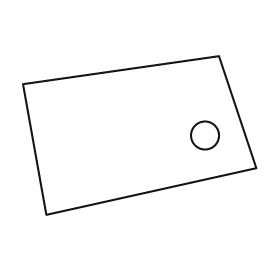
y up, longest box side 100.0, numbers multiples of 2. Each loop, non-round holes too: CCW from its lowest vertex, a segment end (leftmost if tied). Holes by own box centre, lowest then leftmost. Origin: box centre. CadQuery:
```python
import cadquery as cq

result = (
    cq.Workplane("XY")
    .moveTo(-40.0, -34.0)
    .lineTo(50.0, -14.0)
    .lineTo(34.0, 34.0)
    .lineTo(-50.0, 22.0)
    .close()
    .moveTo(28.0, 0.0)
    .circle(6.0)
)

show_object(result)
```